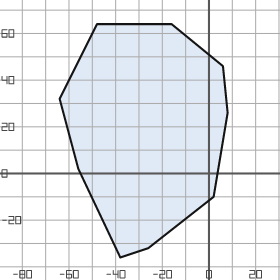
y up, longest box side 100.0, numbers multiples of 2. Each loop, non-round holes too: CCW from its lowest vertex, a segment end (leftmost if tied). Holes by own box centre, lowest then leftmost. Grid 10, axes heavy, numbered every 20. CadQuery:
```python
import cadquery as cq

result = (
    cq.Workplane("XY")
    .moveTo(-38.0, -36.0)
    .lineTo(-26.0, -32.0)
    .lineTo(2.0, -10.0)
    .lineTo(8.0, 26.0)
    .lineTo(6.0, 46.0)
    .lineTo(-16.0, 64.0)
    .lineTo(-48.0, 64.0)
    .lineTo(-64.0, 32.0)
    .lineTo(-56.0, 2.0)
    .close()
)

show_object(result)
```